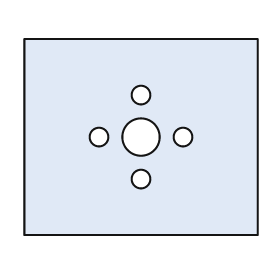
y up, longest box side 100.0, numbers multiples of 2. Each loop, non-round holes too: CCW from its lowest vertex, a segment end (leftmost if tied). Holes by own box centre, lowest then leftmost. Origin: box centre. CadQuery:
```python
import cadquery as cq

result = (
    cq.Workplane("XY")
    .moveTo(-50.0, -42.0)
    .lineTo(50.0, -42.0)
    .lineTo(50.0, 42.0)
    .lineTo(-50.0, 42.0)
    .close()
    .moveTo(0.0, -18.0)
    .circle(4.0)
    .moveTo(-18.0, 0.0)
    .circle(4.0)
    .moveTo(0.0, 0.0)
    .circle(8.0)
    .moveTo(18.0, 0.0)
    .circle(4.0)
    .moveTo(0.0, 18.0)
    .circle(4.0)
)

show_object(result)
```